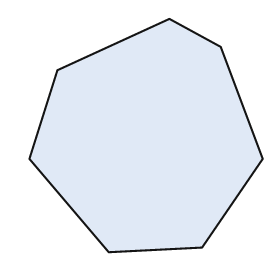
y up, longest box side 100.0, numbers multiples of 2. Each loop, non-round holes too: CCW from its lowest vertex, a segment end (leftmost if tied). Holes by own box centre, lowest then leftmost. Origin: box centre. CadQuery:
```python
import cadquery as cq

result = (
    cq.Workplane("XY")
    .moveTo(-16.0, -50.0)
    .lineTo(24.0, -48.0)
    .lineTo(50.0, -10.0)
    .lineTo(32.0, 38.0)
    .lineTo(10.0, 50.0)
    .lineTo(-38.0, 28.0)
    .lineTo(-50.0, -10.0)
    .close()
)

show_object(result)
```